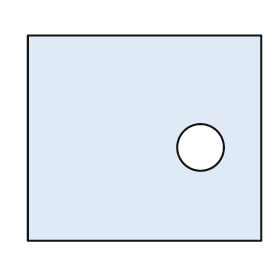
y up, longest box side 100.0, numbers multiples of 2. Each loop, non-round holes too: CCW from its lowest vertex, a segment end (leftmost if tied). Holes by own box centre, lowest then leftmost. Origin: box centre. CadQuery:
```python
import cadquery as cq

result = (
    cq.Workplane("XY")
    .moveTo(-50.0, -44.0)
    .lineTo(50.0, -44.0)
    .lineTo(50.0, 44.0)
    .lineTo(-50.0, 44.0)
    .close()
    .moveTo(24.0, -4.0)
    .circle(10.0)
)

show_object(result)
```